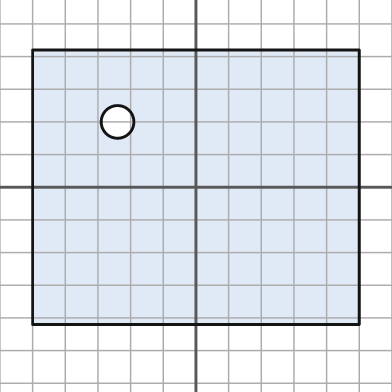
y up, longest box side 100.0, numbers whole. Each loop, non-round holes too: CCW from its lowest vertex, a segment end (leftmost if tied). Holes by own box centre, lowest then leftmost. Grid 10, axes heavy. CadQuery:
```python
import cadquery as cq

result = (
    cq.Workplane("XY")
    .moveTo(-50.0, -42.0)
    .lineTo(50.0, -42.0)
    .lineTo(50.0, 42.0)
    .lineTo(-50.0, 42.0)
    .close()
    .moveTo(-24.0, 20.0)
    .circle(5.0)
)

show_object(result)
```